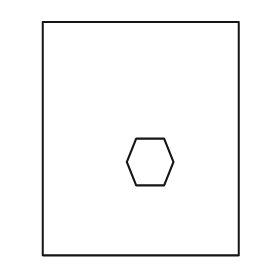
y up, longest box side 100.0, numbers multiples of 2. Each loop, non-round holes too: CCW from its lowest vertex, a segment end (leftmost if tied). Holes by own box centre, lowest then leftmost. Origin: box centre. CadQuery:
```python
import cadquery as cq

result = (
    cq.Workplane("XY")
    .moveTo(-42.0, -50.0)
    .lineTo(42.0, -50.0)
    .lineTo(42.0, 50.0)
    .lineTo(-42.0, 50.0)
    .close()
    .moveTo(-2.0, -20.0)
    .lineTo(10.0, -20.0)
    .lineTo(14.0, -10.0)
    .lineTo(10.0, 0.0)
    .lineTo(-2.0, 0.0)
    .lineTo(-6.0, -10.0)
    .close()
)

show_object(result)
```